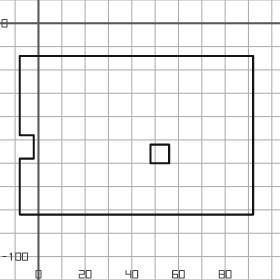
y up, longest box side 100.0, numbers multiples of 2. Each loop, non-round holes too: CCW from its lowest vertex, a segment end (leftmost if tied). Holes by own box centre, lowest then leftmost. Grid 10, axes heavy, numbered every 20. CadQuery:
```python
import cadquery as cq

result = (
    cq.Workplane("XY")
    .moveTo(-8.0, -82.0)
    .lineTo(92.0, -82.0)
    .lineTo(92.0, -14.0)
    .lineTo(-8.0, -14.0)
    .lineTo(-8.0, -48.0)
    .lineTo(-2.0, -48.0)
    .lineTo(-2.0, -58.0)
    .lineTo(-8.0, -58.0)
    .close()
    .moveTo(48.0, -60.0)
    .lineTo(56.0, -60.0)
    .lineTo(56.0, -52.0)
    .lineTo(48.0, -52.0)
    .close()
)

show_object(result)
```